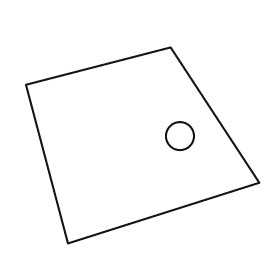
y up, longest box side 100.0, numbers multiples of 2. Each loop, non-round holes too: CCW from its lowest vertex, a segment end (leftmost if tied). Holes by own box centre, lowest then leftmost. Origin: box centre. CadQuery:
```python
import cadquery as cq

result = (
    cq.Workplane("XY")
    .moveTo(-32.0, -42.0)
    .lineTo(50.0, -16.0)
    .lineTo(12.0, 42.0)
    .lineTo(-50.0, 26.0)
    .close()
    .moveTo(16.0, 4.0)
    .circle(6.0)
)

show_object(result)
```